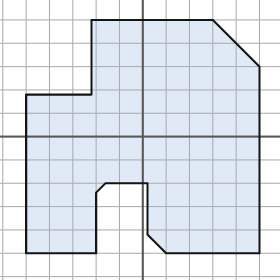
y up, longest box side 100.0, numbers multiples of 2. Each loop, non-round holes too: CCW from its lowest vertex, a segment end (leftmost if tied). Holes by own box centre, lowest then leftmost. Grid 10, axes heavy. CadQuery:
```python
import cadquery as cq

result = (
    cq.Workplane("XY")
    .moveTo(-50.0, -50.0)
    .lineTo(-20.0, -50.0)
    .lineTo(-20.0, -24.0)
    .lineTo(-16.0, -20.0)
    .lineTo(2.0, -20.0)
    .lineTo(2.0, -42.0)
    .lineTo(10.0, -50.0)
    .lineTo(50.0, -50.0)
    .lineTo(50.0, 30.0)
    .lineTo(30.0, 50.0)
    .lineTo(-22.0, 50.0)
    .lineTo(-22.0, 18.0)
    .lineTo(-50.0, 18.0)
    .close()
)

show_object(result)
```